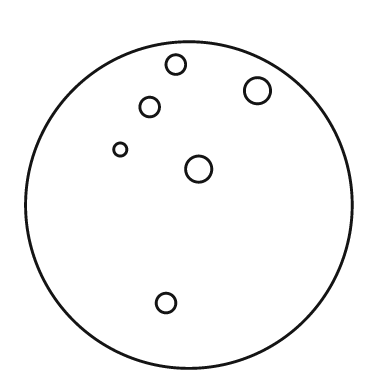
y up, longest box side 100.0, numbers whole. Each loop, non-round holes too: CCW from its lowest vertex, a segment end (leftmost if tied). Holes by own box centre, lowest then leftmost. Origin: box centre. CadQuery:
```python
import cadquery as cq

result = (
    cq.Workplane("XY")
    .moveTo(0.0, 0.0)
    .circle(50.0)
    .moveTo(-7.0, -30.0)
    .circle(3.0)
    .moveTo(3.0, 11.0)
    .circle(4.0)
    .moveTo(-21.0, 17.0)
    .circle(2.0)
    .moveTo(-12.0, 30.0)
    .circle(3.0)
    .moveTo(21.0, 35.0)
    .circle(4.0)
    .moveTo(-4.0, 43.0)
    .circle(3.0)
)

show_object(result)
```